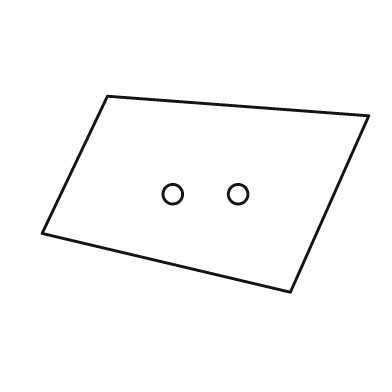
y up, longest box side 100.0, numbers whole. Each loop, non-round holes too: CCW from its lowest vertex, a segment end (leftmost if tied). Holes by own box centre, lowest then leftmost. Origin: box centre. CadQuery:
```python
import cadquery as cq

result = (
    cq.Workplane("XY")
    .moveTo(26.0, -30.0)
    .lineTo(50.0, 24.0)
    .lineTo(-30.0, 30.0)
    .lineTo(-50.0, -12.0)
    .close()
    .moveTo(-10.0, 0.0)
    .circle(3.0)
    .moveTo(10.0, 0.0)
    .circle(3.0)
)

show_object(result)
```